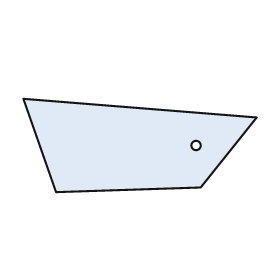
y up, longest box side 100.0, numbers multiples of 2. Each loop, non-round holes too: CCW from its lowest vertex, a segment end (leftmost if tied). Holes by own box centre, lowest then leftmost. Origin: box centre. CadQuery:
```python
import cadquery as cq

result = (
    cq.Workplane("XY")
    .moveTo(-36.0, -20.0)
    .lineTo(26.0, -18.0)
    .lineTo(50.0, 12.0)
    .lineTo(-50.0, 20.0)
    .close()
    .moveTo(24.0, 0.0)
    .circle(2.0)
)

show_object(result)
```